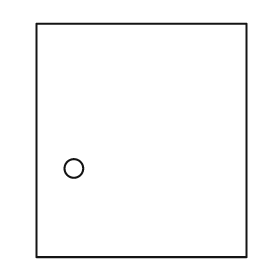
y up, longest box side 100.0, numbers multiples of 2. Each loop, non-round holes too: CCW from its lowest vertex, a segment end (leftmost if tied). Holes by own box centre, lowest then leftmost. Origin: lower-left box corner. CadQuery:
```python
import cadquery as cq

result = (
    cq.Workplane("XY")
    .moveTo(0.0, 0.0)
    .lineTo(90.0, 0.0)
    .lineTo(90.0, 100.0)
    .lineTo(0.0, 100.0)
    .close()
    .moveTo(16.0, 38.0)
    .circle(4.0)
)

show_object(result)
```